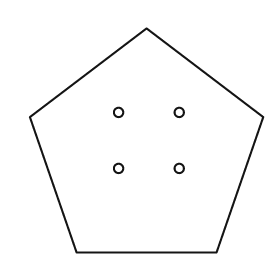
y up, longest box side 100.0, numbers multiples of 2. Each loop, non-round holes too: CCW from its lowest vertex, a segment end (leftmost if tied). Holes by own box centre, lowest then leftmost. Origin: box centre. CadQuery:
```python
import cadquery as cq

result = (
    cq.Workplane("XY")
    .moveTo(-30.0, -48.0)
    .lineTo(30.0, -48.0)
    .lineTo(50.0, 10.0)
    .lineTo(0.0, 48.0)
    .lineTo(-50.0, 10.0)
    .close()
    .moveTo(-12.0, -12.0)
    .circle(2.0)
    .moveTo(14.0, -12.0)
    .circle(2.0)
    .moveTo(-12.0, 12.0)
    .circle(2.0)
    .moveTo(14.0, 12.0)
    .circle(2.0)
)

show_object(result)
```